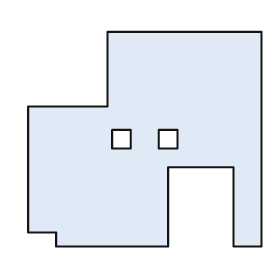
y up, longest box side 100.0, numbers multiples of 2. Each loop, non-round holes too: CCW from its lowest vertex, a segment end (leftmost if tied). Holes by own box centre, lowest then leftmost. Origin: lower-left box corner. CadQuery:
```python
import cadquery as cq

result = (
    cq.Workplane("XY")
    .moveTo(12.0, 0.0)
    .lineTo(60.0, 0.0)
    .lineTo(60.0, 34.0)
    .lineTo(88.0, 34.0)
    .lineTo(88.0, 0.0)
    .lineTo(100.0, 0.0)
    .lineTo(100.0, 92.0)
    .lineTo(34.0, 92.0)
    .lineTo(34.0, 60.0)
    .lineTo(0.0, 60.0)
    .lineTo(0.0, 6.0)
    .lineTo(12.0, 6.0)
    .close()
    .moveTo(36.0, 42.0)
    .lineTo(44.0, 42.0)
    .lineTo(44.0, 50.0)
    .lineTo(36.0, 50.0)
    .close()
    .moveTo(56.0, 42.0)
    .lineTo(64.0, 42.0)
    .lineTo(64.0, 50.0)
    .lineTo(56.0, 50.0)
    .close()
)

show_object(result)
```